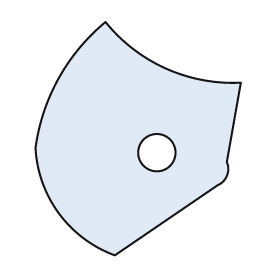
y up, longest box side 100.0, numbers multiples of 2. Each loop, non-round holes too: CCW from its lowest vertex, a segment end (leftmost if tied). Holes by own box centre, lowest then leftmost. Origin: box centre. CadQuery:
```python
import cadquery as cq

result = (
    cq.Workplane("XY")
    .moveTo(-10.0, -50.0)
    .lineTo(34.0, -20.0)
    .threePointArc((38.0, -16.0), (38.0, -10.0))
    .lineTo(44.0, 24.0)
    .threePointArc((12.0, 30.0), (-14.0, 50.0))
    .threePointArc((-34.0, 26.0), (-44.0, -4.0))
    .threePointArc((-34.0, -32.0), (-10.0, -50.0))
    .close()
    .moveTo(8.0, -6.0)
    .circle(8.0)
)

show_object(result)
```